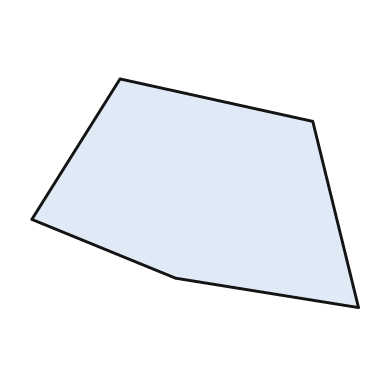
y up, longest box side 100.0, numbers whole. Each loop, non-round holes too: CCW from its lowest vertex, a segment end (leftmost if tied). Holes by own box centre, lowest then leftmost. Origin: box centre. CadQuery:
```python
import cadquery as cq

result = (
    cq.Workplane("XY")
    .moveTo(50.0, -35.0)
    .lineTo(36.0, 22.0)
    .lineTo(-23.0, 35.0)
    .lineTo(-50.0, -8.0)
    .lineTo(-6.0, -26.0)
    .close()
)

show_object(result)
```